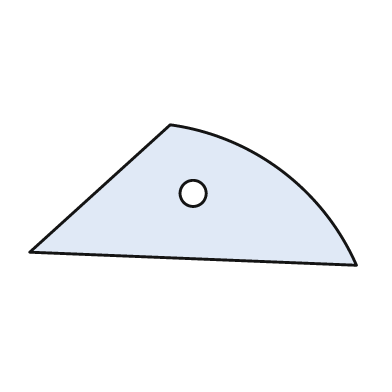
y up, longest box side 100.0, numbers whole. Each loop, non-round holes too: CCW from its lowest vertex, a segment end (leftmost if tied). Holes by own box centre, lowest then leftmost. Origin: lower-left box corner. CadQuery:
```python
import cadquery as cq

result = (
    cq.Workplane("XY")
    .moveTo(100.0, 0.0)
    .threePointArc((77.0, 29.0), (43.0, 43.0))
    .lineTo(0.0, 4.0)
    .close()
    .moveTo(50.0, 22.0)
    .circle(4.0)
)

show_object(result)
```